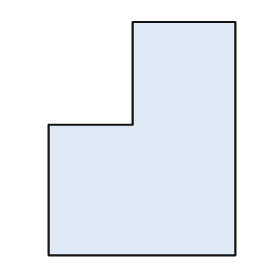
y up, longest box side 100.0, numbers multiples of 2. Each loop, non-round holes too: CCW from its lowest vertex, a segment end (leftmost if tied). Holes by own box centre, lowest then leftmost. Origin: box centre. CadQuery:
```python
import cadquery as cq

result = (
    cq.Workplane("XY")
    .moveTo(-40.0, -50.0)
    .lineTo(40.0, -50.0)
    .lineTo(40.0, 50.0)
    .lineTo(-4.0, 50.0)
    .lineTo(-4.0, 6.0)
    .lineTo(-40.0, 6.0)
    .close()
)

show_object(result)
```